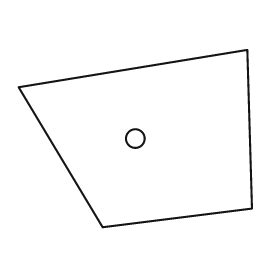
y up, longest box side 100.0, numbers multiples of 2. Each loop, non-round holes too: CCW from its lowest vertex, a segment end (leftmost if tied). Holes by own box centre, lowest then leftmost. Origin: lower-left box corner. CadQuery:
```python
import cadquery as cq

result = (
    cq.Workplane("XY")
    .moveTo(36.0, 0.0)
    .lineTo(100.0, 8.0)
    .lineTo(98.0, 76.0)
    .lineTo(0.0, 60.0)
    .close()
    .moveTo(50.0, 38.0)
    .circle(4.0)
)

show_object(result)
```